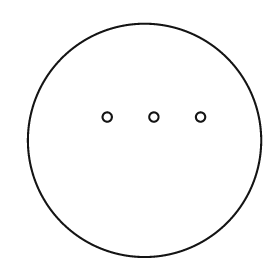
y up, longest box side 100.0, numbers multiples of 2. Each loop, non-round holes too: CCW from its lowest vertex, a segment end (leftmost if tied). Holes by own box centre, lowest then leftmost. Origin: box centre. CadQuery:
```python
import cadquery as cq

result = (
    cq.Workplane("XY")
    .moveTo(0.0, 0.0)
    .circle(50.0)
    .moveTo(-16.0, 10.0)
    .circle(2.0)
    .moveTo(4.0, 10.0)
    .circle(2.0)
    .moveTo(24.0, 10.0)
    .circle(2.0)
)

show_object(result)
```